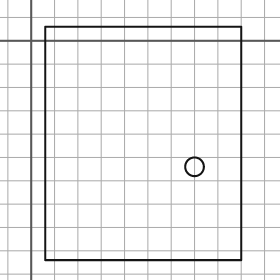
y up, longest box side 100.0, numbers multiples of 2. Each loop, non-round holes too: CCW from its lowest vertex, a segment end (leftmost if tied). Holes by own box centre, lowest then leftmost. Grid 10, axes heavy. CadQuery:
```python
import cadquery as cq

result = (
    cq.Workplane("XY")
    .moveTo(6.0, -94.0)
    .lineTo(90.0, -94.0)
    .lineTo(90.0, 6.0)
    .lineTo(6.0, 6.0)
    .close()
    .moveTo(70.0, -54.0)
    .circle(4.0)
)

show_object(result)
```